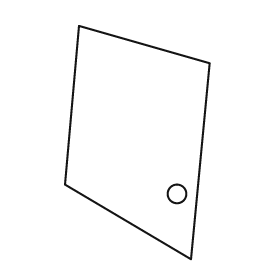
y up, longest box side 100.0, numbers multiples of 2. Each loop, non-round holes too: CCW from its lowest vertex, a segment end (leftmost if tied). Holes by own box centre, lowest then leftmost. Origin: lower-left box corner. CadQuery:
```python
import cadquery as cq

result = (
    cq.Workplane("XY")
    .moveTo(54.0, 0.0)
    .lineTo(62.0, 84.0)
    .lineTo(6.0, 100.0)
    .lineTo(0.0, 32.0)
    .close()
    .moveTo(48.0, 28.0)
    .circle(4.0)
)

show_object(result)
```